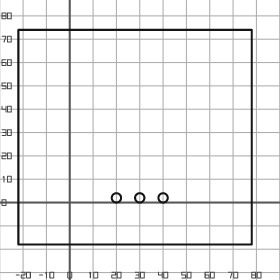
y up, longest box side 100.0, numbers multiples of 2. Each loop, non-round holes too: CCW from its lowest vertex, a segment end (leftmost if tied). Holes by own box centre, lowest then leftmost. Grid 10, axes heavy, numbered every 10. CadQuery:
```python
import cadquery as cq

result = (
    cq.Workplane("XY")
    .moveTo(-22.0, -18.0)
    .lineTo(78.0, -18.0)
    .lineTo(78.0, 74.0)
    .lineTo(-22.0, 74.0)
    .close()
    .moveTo(20.0, 2.0)
    .circle(2.0)
    .moveTo(30.0, 2.0)
    .circle(2.0)
    .moveTo(40.0, 2.0)
    .circle(2.0)
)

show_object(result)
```